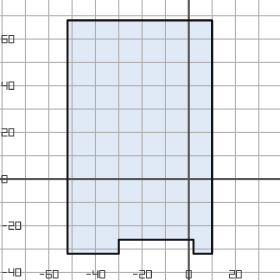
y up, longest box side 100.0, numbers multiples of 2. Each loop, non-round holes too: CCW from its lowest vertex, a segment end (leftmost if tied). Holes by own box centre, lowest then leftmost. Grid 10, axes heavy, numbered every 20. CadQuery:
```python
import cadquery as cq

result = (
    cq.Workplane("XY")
    .moveTo(-52.0, -32.0)
    .lineTo(-30.0, -32.0)
    .lineTo(-30.0, -26.0)
    .lineTo(2.0, -26.0)
    .lineTo(2.0, -32.0)
    .lineTo(10.0, -32.0)
    .lineTo(10.0, 68.0)
    .lineTo(-52.0, 68.0)
    .close()
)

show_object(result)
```